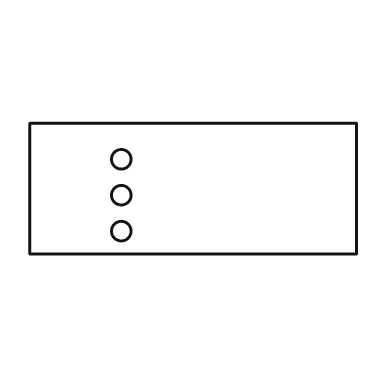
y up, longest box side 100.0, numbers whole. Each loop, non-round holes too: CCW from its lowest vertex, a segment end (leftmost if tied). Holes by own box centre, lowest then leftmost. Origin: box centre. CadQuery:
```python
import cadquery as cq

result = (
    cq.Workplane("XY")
    .moveTo(-50.0, -20.0)
    .lineTo(50.0, -20.0)
    .lineTo(50.0, 20.0)
    .lineTo(-50.0, 20.0)
    .close()
    .moveTo(-22.0, -13.0)
    .circle(3.0)
    .moveTo(-22.0, -2.0)
    .circle(3.0)
    .moveTo(-22.0, 9.0)
    .circle(3.0)
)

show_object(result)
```